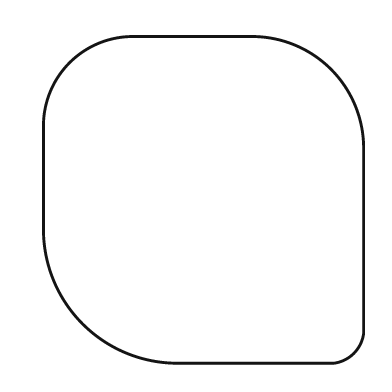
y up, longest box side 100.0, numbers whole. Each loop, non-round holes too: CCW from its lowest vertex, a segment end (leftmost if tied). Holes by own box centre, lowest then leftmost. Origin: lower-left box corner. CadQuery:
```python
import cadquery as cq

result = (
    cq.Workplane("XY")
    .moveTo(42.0, 0.0)
    .lineTo(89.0, 0.0)
    .threePointArc((95.0, 3.0), (98.0, 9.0))
    .lineTo(98.0, 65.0)
    .threePointArc((88.0, 90.0), (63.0, 100.0))
    .lineTo(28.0, 100.0)
    .threePointArc((8.0, 92.0), (0.0, 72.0))
    .lineTo(0.0, 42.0)
    .threePointArc((12.0, 12.0), (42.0, 0.0))
    .close()
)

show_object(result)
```